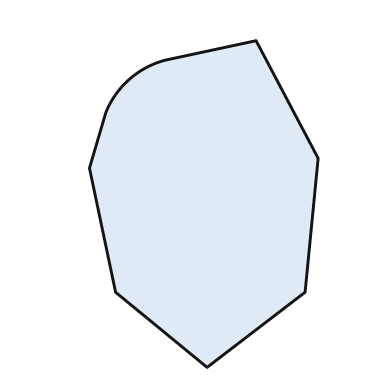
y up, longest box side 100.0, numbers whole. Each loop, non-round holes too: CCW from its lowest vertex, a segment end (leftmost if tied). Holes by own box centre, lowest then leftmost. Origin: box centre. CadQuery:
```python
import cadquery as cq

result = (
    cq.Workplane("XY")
    .moveTo(1.0, -50.0)
    .lineTo(31.0, -27.0)
    .lineTo(35.0, 14.0)
    .lineTo(16.0, 50.0)
    .lineTo(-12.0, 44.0)
    .threePointArc((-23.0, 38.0), (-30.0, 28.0))
    .lineTo(-35.0, 11.0)
    .lineTo(-27.0, -27.0)
    .close()
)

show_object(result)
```